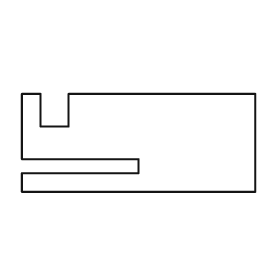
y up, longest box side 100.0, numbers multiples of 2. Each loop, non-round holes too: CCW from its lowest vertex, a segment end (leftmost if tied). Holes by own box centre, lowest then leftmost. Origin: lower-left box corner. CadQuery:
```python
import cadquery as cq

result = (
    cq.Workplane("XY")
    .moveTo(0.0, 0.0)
    .lineTo(100.0, 0.0)
    .lineTo(100.0, 42.0)
    .lineTo(20.0, 42.0)
    .lineTo(20.0, 28.0)
    .lineTo(8.0, 28.0)
    .lineTo(8.0, 42.0)
    .lineTo(0.0, 42.0)
    .lineTo(0.0, 14.0)
    .lineTo(50.0, 14.0)
    .lineTo(50.0, 8.0)
    .lineTo(0.0, 8.0)
    .close()
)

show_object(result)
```